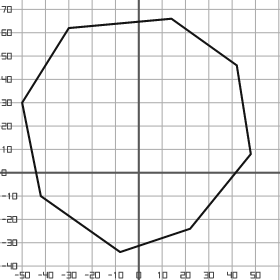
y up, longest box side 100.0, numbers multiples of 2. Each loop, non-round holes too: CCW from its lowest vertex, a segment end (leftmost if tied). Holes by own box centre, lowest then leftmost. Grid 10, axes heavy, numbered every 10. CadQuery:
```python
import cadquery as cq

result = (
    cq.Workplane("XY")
    .moveTo(-8.0, -34.0)
    .lineTo(22.0, -24.0)
    .lineTo(48.0, 8.0)
    .lineTo(42.0, 46.0)
    .lineTo(14.0, 66.0)
    .lineTo(-30.0, 62.0)
    .lineTo(-50.0, 30.0)
    .lineTo(-42.0, -10.0)
    .close()
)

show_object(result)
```